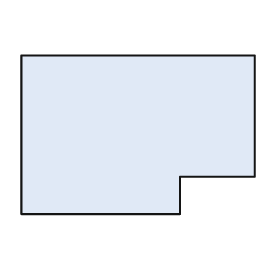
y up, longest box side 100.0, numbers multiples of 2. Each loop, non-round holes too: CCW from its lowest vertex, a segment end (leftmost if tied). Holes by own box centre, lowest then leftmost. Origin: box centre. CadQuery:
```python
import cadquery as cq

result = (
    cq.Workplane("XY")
    .moveTo(-50.0, -34.0)
    .lineTo(18.0, -34.0)
    .lineTo(18.0, -18.0)
    .lineTo(50.0, -18.0)
    .lineTo(50.0, 34.0)
    .lineTo(-50.0, 34.0)
    .close()
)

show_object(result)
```